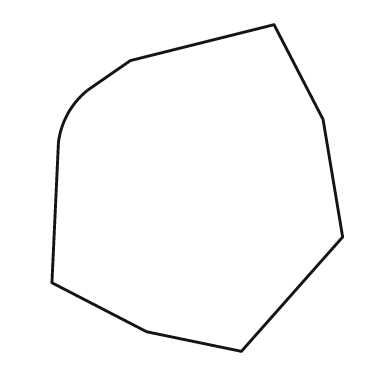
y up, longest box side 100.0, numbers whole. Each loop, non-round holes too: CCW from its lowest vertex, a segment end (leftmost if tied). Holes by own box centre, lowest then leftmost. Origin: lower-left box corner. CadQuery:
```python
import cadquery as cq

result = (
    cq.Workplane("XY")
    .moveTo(58.0, 0.0)
    .lineTo(89.0, 35.0)
    .lineTo(83.0, 71.0)
    .lineTo(68.0, 100.0)
    .lineTo(24.0, 89.0)
    .lineTo(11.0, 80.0)
    .threePointArc((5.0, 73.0), (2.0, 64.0))
    .lineTo(0.0, 21.0)
    .lineTo(29.0, 6.0)
    .close()
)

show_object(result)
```